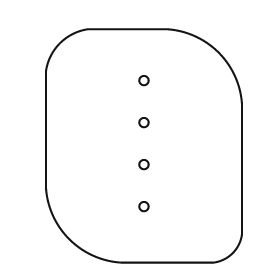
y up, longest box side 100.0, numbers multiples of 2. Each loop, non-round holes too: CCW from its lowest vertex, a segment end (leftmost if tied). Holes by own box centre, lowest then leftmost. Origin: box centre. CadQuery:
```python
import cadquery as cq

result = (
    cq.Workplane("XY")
    .moveTo(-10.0, -50.0)
    .lineTo(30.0, -50.0)
    .threePointArc((38.0, -46.0), (42.0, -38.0))
    .lineTo(42.0, 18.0)
    .threePointArc((32.0, 40.0), (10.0, 50.0))
    .lineTo(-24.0, 50.0)
    .threePointArc((-36.0, 44.0), (-42.0, 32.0))
    .lineTo(-42.0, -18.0)
    .threePointArc((-32.0, -40.0), (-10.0, -50.0))
    .close()
    .moveTo(0.0, -26.0)
    .circle(2.0)
    .moveTo(0.0, -8.0)
    .circle(2.0)
    .moveTo(0.0, 10.0)
    .circle(2.0)
    .moveTo(0.0, 28.0)
    .circle(2.0)
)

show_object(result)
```